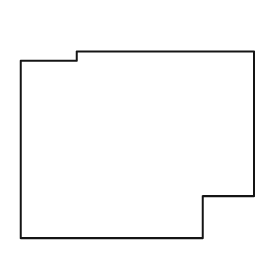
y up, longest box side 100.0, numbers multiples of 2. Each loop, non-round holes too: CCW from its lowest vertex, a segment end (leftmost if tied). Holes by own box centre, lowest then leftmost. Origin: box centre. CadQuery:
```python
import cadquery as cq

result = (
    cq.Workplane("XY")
    .moveTo(-50.0, -40.0)
    .lineTo(28.0, -40.0)
    .lineTo(28.0, -22.0)
    .lineTo(50.0, -22.0)
    .lineTo(50.0, 40.0)
    .lineTo(-26.0, 40.0)
    .lineTo(-26.0, 36.0)
    .lineTo(-50.0, 36.0)
    .close()
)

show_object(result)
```